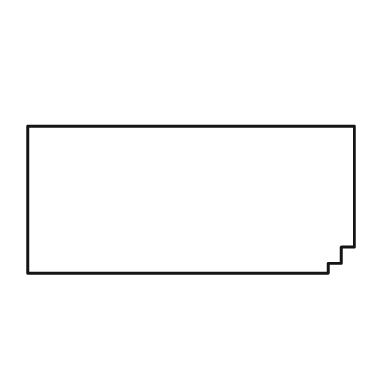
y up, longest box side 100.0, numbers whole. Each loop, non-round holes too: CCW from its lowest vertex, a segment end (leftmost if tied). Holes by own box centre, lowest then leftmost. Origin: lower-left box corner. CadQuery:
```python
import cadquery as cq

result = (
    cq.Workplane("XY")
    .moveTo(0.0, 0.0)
    .lineTo(92.0, 0.0)
    .lineTo(92.0, 3.0)
    .lineTo(96.0, 3.0)
    .lineTo(96.0, 8.0)
    .lineTo(100.0, 8.0)
    .lineTo(100.0, 45.0)
    .lineTo(0.0, 45.0)
    .close()
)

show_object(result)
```